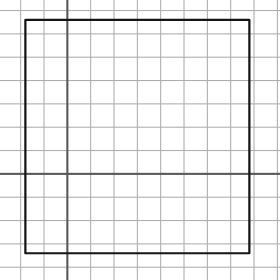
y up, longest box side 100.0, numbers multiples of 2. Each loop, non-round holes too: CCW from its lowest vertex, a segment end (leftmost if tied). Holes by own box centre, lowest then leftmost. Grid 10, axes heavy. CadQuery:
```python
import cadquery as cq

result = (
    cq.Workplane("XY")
    .moveTo(-18.0, -34.0)
    .lineTo(78.0, -34.0)
    .lineTo(78.0, 66.0)
    .lineTo(-18.0, 66.0)
    .close()
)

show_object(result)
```